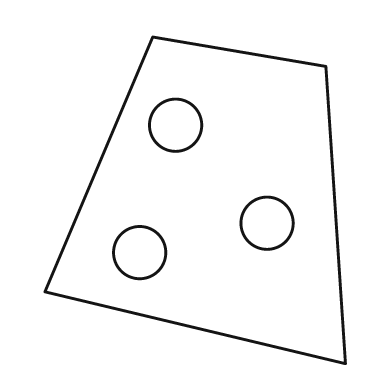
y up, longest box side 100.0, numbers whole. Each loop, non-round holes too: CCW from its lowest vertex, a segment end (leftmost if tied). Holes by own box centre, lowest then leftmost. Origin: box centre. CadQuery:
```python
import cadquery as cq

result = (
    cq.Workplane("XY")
    .moveTo(46.0, -50.0)
    .lineTo(40.0, 41.0)
    .lineTo(-13.0, 50.0)
    .lineTo(-46.0, -28.0)
    .close()
    .moveTo(-17.0, -16.0)
    .circle(8.0)
    .moveTo(22.0, -7.0)
    .circle(8.0)
    .moveTo(-6.0, 23.0)
    .circle(8.0)
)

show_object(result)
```